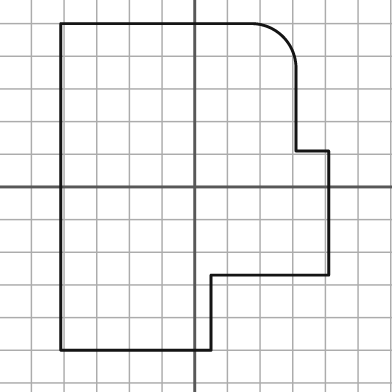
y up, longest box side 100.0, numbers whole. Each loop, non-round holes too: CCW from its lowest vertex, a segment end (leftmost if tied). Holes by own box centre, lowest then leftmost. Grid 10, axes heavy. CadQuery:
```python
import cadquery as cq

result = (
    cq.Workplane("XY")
    .moveTo(-41.0, -50.0)
    .lineTo(5.0, -50.0)
    .lineTo(5.0, -27.0)
    .lineTo(41.0, -27.0)
    .lineTo(41.0, 11.0)
    .lineTo(31.0, 11.0)
    .lineTo(31.0, 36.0)
    .threePointArc((27.0, 46.0), (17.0, 50.0))
    .lineTo(-41.0, 50.0)
    .close()
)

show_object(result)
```